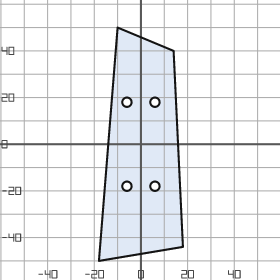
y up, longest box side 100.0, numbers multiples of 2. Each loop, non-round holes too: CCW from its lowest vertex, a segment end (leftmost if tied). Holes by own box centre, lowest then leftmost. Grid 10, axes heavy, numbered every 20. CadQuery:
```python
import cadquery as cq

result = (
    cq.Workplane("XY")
    .moveTo(-18.0, -50.0)
    .lineTo(18.0, -44.0)
    .lineTo(14.0, 40.0)
    .lineTo(-10.0, 50.0)
    .close()
    .moveTo(-6.0, -18.0)
    .circle(2.0)
    .moveTo(6.0, -18.0)
    .circle(2.0)
    .moveTo(-6.0, 18.0)
    .circle(2.0)
    .moveTo(6.0, 18.0)
    .circle(2.0)
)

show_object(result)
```